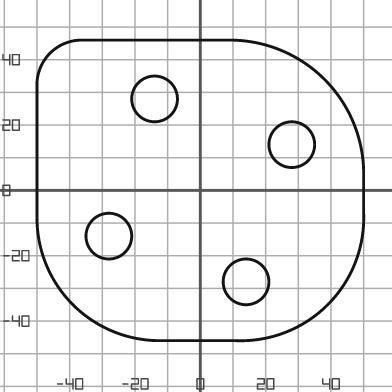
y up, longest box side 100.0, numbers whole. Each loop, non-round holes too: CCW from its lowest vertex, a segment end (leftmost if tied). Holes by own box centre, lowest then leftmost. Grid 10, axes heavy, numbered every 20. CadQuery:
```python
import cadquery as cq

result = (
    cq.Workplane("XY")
    .moveTo(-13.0, -46.0)
    .lineTo(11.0, -46.0)
    .threePointArc((39.0, -35.0), (50.0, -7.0))
    .lineTo(50.0, 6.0)
    .threePointArc((38.0, 34.0), (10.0, 46.0))
    .lineTo(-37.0, 46.0)
    .threePointArc((-46.0, 42.0), (-50.0, 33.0))
    .lineTo(-50.0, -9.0)
    .threePointArc((-39.0, -35.0), (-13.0, -46.0))
    .close()
    .moveTo(14.0, -28.0)
    .circle(7.0)
    .moveTo(-28.0, -14.0)
    .circle(7.0)
    .moveTo(28.0, 14.0)
    .circle(7.0)
    .moveTo(-14.0, 28.0)
    .circle(7.0)
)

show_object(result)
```